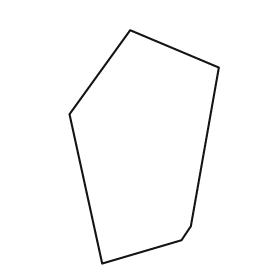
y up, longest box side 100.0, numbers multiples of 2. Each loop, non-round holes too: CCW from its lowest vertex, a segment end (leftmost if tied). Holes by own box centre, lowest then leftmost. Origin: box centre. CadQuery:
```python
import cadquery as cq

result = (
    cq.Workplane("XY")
    .moveTo(-18.0, -50.0)
    .lineTo(16.0, -40.0)
    .lineTo(20.0, -34.0)
    .lineTo(32.0, 34.0)
    .lineTo(-6.0, 50.0)
    .lineTo(-32.0, 14.0)
    .close()
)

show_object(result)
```